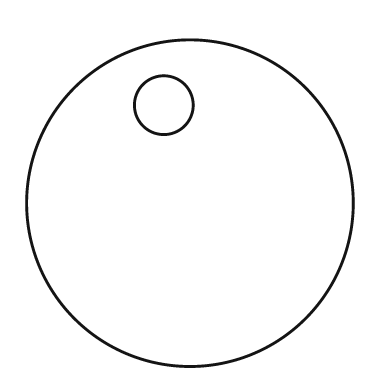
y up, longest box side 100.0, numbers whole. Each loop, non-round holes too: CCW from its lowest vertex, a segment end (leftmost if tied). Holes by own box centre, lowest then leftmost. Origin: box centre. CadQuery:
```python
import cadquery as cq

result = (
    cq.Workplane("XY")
    .moveTo(0.0, 0.0)
    .circle(50.0)
    .moveTo(-8.0, 30.0)
    .circle(9.0)
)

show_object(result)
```